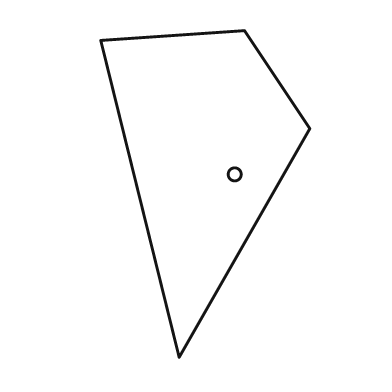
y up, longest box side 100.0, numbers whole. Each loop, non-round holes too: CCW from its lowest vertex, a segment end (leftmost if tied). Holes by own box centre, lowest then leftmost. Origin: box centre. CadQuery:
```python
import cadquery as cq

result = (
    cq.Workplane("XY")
    .moveTo(-8.0, -50.0)
    .lineTo(32.0, 20.0)
    .lineTo(12.0, 50.0)
    .lineTo(-32.0, 47.0)
    .close()
    .moveTo(9.0, 6.0)
    .circle(2.0)
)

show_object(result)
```